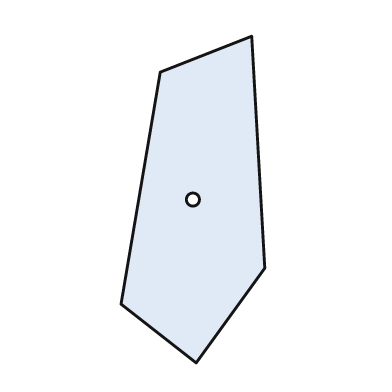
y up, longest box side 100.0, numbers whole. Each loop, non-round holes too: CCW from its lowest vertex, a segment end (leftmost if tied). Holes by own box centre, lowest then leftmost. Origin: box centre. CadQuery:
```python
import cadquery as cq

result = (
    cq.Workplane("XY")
    .moveTo(1.0, -50.0)
    .lineTo(22.0, -21.0)
    .lineTo(18.0, 50.0)
    .lineTo(-10.0, 39.0)
    .lineTo(-22.0, -32.0)
    .close()
    .moveTo(0.0, 0.0)
    .circle(2.0)
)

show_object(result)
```